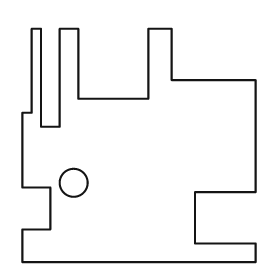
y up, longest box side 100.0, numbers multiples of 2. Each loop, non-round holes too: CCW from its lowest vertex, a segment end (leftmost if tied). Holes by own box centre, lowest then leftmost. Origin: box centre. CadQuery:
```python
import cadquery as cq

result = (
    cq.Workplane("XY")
    .moveTo(-50.0, -50.0)
    .lineTo(50.0, -50.0)
    .lineTo(50.0, -42.0)
    .lineTo(24.0, -42.0)
    .lineTo(24.0, -20.0)
    .lineTo(50.0, -20.0)
    .lineTo(50.0, 28.0)
    .lineTo(14.0, 28.0)
    .lineTo(14.0, 50.0)
    .lineTo(4.0, 50.0)
    .lineTo(4.0, 20.0)
    .lineTo(-26.0, 20.0)
    .lineTo(-26.0, 50.0)
    .lineTo(-34.0, 50.0)
    .lineTo(-34.0, 8.0)
    .lineTo(-42.0, 8.0)
    .lineTo(-42.0, 50.0)
    .lineTo(-46.0, 50.0)
    .lineTo(-46.0, 14.0)
    .lineTo(-50.0, 14.0)
    .lineTo(-50.0, -18.0)
    .lineTo(-38.0, -18.0)
    .lineTo(-38.0, -36.0)
    .lineTo(-50.0, -36.0)
    .close()
    .moveTo(-28.0, -16.0)
    .circle(6.0)
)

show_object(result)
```